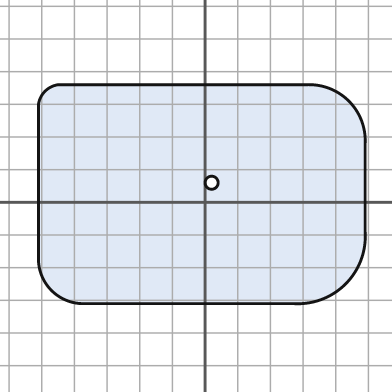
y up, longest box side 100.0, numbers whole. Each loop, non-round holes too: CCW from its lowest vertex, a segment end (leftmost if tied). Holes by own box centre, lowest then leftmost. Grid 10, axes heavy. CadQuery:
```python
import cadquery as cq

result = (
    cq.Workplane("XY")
    .moveTo(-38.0, -31.0)
    .lineTo(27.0, -31.0)
    .threePointArc((43.0, -25.0), (49.0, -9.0))
    .lineTo(49.0, 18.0)
    .threePointArc((44.0, 31.0), (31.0, 36.0))
    .lineTo(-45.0, 36.0)
    .threePointArc((-49.0, 34.0), (-51.0, 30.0))
    .lineTo(-51.0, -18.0)
    .threePointArc((-47.0, -27.0), (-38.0, -31.0))
    .close()
    .moveTo(2.0, 6.0)
    .circle(2.0)
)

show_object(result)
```